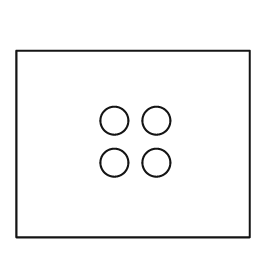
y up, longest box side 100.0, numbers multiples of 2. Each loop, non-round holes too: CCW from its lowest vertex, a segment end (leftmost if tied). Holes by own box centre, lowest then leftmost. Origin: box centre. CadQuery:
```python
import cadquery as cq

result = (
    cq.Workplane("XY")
    .moveTo(-50.0, -40.0)
    .lineTo(50.0, -40.0)
    .lineTo(50.0, 40.0)
    .lineTo(-50.0, 40.0)
    .close()
    .moveTo(-8.0, -8.0)
    .circle(6.0)
    .moveTo(10.0, -8.0)
    .circle(6.0)
    .moveTo(-8.0, 10.0)
    .circle(6.0)
    .moveTo(10.0, 10.0)
    .circle(6.0)
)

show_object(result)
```